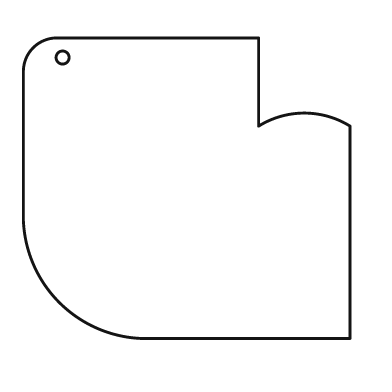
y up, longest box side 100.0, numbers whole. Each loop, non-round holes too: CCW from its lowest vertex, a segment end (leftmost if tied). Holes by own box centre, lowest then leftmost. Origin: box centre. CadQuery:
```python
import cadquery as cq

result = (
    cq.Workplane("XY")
    .moveTo(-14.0, -46.0)
    .lineTo(50.0, -46.0)
    .lineTo(50.0, 19.0)
    .threePointArc((36.0, 23.0), (22.0, 19.0))
    .lineTo(22.0, 46.0)
    .lineTo(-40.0, 46.0)
    .threePointArc((-47.0, 43.0), (-50.0, 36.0))
    .lineTo(-50.0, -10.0)
    .threePointArc((-39.0, -35.0), (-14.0, -46.0))
    .close()
    .moveTo(-38.0, 40.0)
    .circle(2.0)
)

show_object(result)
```